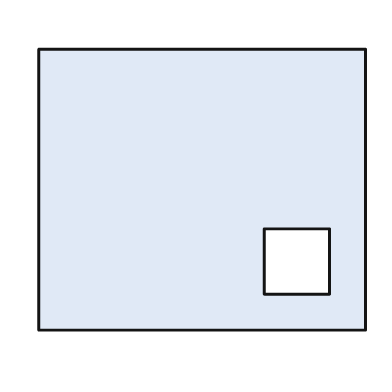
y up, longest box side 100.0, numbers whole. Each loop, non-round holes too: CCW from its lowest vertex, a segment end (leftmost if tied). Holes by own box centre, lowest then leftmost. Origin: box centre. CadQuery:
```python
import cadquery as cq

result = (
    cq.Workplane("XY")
    .moveTo(-50.0, -43.0)
    .lineTo(50.0, -43.0)
    .lineTo(50.0, 43.0)
    .lineTo(-50.0, 43.0)
    .close()
    .moveTo(19.0, -32.0)
    .lineTo(39.0, -32.0)
    .lineTo(39.0, -12.0)
    .lineTo(19.0, -12.0)
    .close()
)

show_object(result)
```